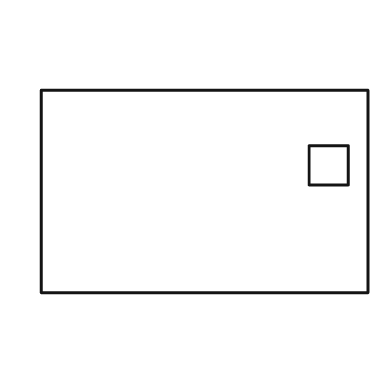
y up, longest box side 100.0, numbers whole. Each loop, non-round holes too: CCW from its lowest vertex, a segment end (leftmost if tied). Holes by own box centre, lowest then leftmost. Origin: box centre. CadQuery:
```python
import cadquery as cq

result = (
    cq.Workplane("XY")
    .moveTo(-50.0, -31.0)
    .lineTo(50.0, -31.0)
    .lineTo(50.0, 31.0)
    .lineTo(-50.0, 31.0)
    .close()
    .moveTo(32.0, 2.0)
    .lineTo(44.0, 2.0)
    .lineTo(44.0, 14.0)
    .lineTo(32.0, 14.0)
    .close()
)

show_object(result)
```